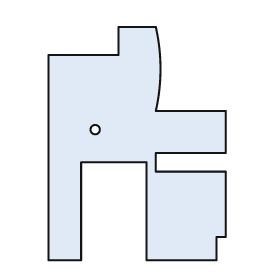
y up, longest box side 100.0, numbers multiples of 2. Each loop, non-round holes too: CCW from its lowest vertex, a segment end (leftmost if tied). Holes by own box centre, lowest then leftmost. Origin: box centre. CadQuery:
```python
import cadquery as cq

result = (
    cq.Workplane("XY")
    .moveTo(-38.0, -50.0)
    .lineTo(-24.0, -50.0)
    .lineTo(-24.0, -8.0)
    .lineTo(4.0, -8.0)
    .lineTo(4.0, -50.0)
    .lineTo(34.0, -50.0)
    .lineTo(34.0, -40.0)
    .lineTo(38.0, -40.0)
    .lineTo(38.0, -12.0)
    .lineTo(8.0, -12.0)
    .lineTo(8.0, -4.0)
    .lineTo(38.0, -4.0)
    .lineTo(38.0, 14.0)
    .lineTo(8.0, 14.0)
    .threePointArc((10.0, 32.0), (8.0, 50.0))
    .lineTo(-8.0, 50.0)
    .lineTo(-8.0, 38.0)
    .lineTo(-38.0, 38.0)
    .close()
    .moveTo(-18.0, 6.0)
    .circle(2.0)
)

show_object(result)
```